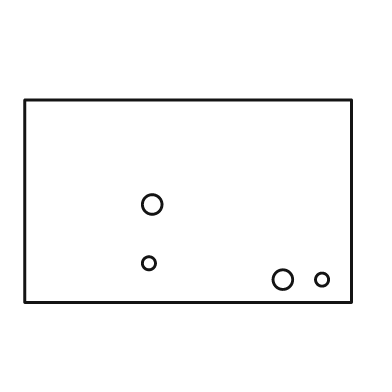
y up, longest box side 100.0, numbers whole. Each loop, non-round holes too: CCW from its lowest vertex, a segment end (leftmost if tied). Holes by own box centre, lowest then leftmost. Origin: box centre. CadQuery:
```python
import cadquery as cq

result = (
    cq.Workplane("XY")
    .moveTo(-50.0, -31.0)
    .lineTo(50.0, -31.0)
    .lineTo(50.0, 31.0)
    .lineTo(-50.0, 31.0)
    .close()
    .moveTo(29.0, -24.0)
    .circle(3.0)
    .moveTo(41.0, -24.0)
    .circle(2.0)
    .moveTo(-12.0, -19.0)
    .circle(2.0)
    .moveTo(-11.0, -1.0)
    .circle(3.0)
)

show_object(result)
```